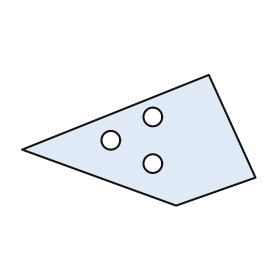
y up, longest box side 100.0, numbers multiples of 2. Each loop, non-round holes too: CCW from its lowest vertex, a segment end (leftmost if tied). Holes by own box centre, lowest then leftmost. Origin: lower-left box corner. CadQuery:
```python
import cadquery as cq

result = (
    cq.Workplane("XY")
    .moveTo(66.0, 0.0)
    .lineTo(100.0, 12.0)
    .lineTo(80.0, 56.0)
    .lineTo(0.0, 24.0)
    .close()
    .moveTo(56.0, 18.0)
    .circle(4.0)
    .moveTo(38.0, 28.0)
    .circle(4.0)
    .moveTo(56.0, 38.0)
    .circle(4.0)
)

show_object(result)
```